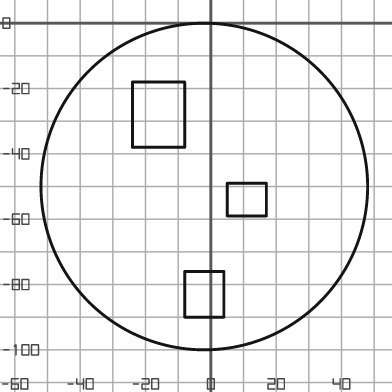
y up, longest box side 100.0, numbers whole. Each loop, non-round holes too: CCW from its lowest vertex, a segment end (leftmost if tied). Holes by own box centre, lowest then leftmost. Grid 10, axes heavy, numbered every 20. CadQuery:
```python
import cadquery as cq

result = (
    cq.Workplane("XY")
    .moveTo(-2.0, -50.0)
    .circle(50.0)
    .moveTo(-8.0, -90.0)
    .lineTo(4.0, -90.0)
    .lineTo(4.0, -76.0)
    .lineTo(-8.0, -76.0)
    .close()
    .moveTo(5.0, -59.0)
    .lineTo(17.0, -59.0)
    .lineTo(17.0, -49.0)
    .lineTo(5.0, -49.0)
    .close()
    .moveTo(-24.0, -38.0)
    .lineTo(-8.0, -38.0)
    .lineTo(-8.0, -18.0)
    .lineTo(-24.0, -18.0)
    .close()
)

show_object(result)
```